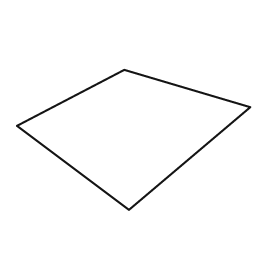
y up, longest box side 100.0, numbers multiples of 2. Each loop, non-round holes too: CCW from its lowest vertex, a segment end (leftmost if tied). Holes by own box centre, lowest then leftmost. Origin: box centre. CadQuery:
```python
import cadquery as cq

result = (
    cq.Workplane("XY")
    .moveTo(-2.0, -30.0)
    .lineTo(50.0, 14.0)
    .lineTo(-4.0, 30.0)
    .lineTo(-50.0, 6.0)
    .close()
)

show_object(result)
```